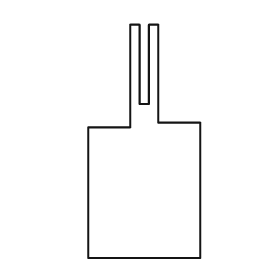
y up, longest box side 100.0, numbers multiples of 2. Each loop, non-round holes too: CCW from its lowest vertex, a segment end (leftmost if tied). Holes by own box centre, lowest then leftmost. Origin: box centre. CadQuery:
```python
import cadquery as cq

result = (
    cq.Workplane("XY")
    .moveTo(-24.0, -50.0)
    .lineTo(24.0, -50.0)
    .lineTo(24.0, 8.0)
    .lineTo(6.0, 8.0)
    .lineTo(6.0, 50.0)
    .lineTo(2.0, 50.0)
    .lineTo(2.0, 16.0)
    .lineTo(-2.0, 16.0)
    .lineTo(-2.0, 50.0)
    .lineTo(-6.0, 50.0)
    .lineTo(-6.0, 6.0)
    .lineTo(-24.0, 6.0)
    .close()
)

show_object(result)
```